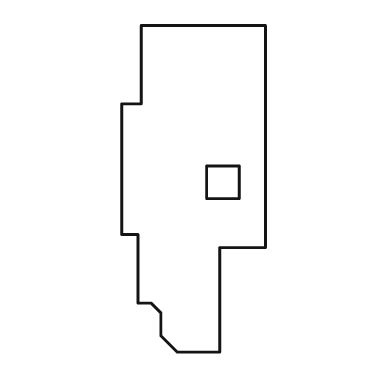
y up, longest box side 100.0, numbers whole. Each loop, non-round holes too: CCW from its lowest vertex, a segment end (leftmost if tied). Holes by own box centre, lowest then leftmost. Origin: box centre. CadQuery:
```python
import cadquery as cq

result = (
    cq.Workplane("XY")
    .moveTo(-5.0, -50.0)
    .lineTo(8.0, -50.0)
    .lineTo(8.0, -18.0)
    .lineTo(22.0, -18.0)
    .lineTo(22.0, 50.0)
    .lineTo(-16.0, 50.0)
    .lineTo(-16.0, 26.0)
    .lineTo(-22.0, 26.0)
    .lineTo(-22.0, -14.0)
    .lineTo(-17.0, -14.0)
    .lineTo(-17.0, -35.0)
    .lineTo(-13.0, -35.0)
    .lineTo(-10.0, -38.0)
    .lineTo(-10.0, -45.0)
    .close()
    .moveTo(4.0, -3.0)
    .lineTo(14.0, -3.0)
    .lineTo(14.0, 7.0)
    .lineTo(4.0, 7.0)
    .close()
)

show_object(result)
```